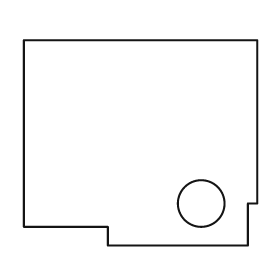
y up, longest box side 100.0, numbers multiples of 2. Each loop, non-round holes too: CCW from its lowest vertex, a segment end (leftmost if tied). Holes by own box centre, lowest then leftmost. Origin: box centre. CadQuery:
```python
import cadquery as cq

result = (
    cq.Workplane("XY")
    .moveTo(-14.0, -44.0)
    .lineTo(46.0, -44.0)
    .lineTo(46.0, -26.0)
    .lineTo(50.0, -26.0)
    .lineTo(50.0, 44.0)
    .lineTo(-50.0, 44.0)
    .lineTo(-50.0, -36.0)
    .lineTo(-14.0, -36.0)
    .close()
    .moveTo(26.0, -26.0)
    .circle(10.0)
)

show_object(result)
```